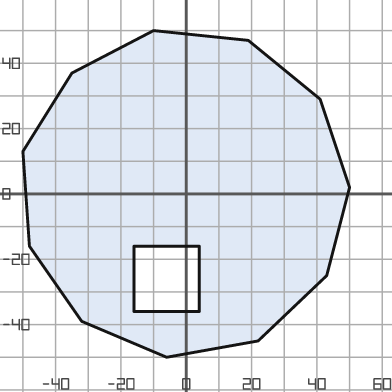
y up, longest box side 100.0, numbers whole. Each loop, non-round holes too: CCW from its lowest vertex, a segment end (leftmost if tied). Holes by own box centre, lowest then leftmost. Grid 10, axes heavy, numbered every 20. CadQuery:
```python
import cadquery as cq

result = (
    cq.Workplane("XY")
    .moveTo(-6.0, -50.0)
    .lineTo(22.0, -45.0)
    .lineTo(43.0, -25.0)
    .lineTo(50.0, 2.0)
    .lineTo(41.0, 29.0)
    .lineTo(19.0, 47.0)
    .lineTo(-10.0, 50.0)
    .lineTo(-35.0, 37.0)
    .lineTo(-50.0, 13.0)
    .lineTo(-48.0, -16.0)
    .lineTo(-32.0, -39.0)
    .close()
    .moveTo(-16.0, -36.0)
    .lineTo(4.0, -36.0)
    .lineTo(4.0, -16.0)
    .lineTo(-16.0, -16.0)
    .close()
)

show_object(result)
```